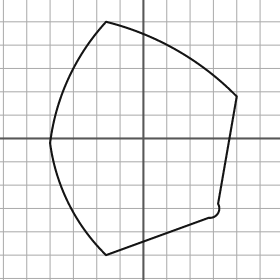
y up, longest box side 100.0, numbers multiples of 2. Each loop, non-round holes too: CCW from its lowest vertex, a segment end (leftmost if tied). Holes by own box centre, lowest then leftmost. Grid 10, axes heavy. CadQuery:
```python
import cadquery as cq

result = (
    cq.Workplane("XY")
    .moveTo(-16.0, -50.0)
    .lineTo(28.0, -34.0)
    .threePointArc((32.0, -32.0), (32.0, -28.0))
    .lineTo(40.0, 18.0)
    .threePointArc((14.0, 38.0), (-16.0, 50.0))
    .threePointArc((-32.0, 26.0), (-40.0, -2.0))
    .threePointArc((-32.0, -28.0), (-16.0, -50.0))
    .close()
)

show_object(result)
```